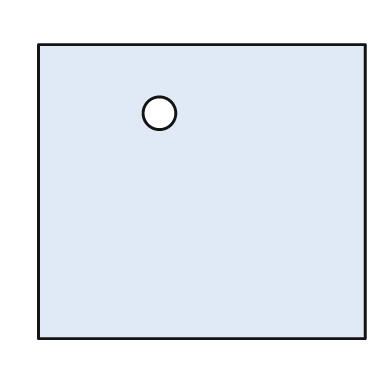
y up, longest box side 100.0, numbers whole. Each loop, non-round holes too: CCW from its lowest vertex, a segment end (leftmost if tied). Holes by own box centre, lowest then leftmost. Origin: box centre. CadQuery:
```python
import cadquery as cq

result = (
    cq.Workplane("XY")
    .moveTo(-50.0, -45.0)
    .lineTo(50.0, -45.0)
    .lineTo(50.0, 45.0)
    .lineTo(-50.0, 45.0)
    .close()
    .moveTo(-13.0, 24.0)
    .circle(5.0)
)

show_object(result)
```